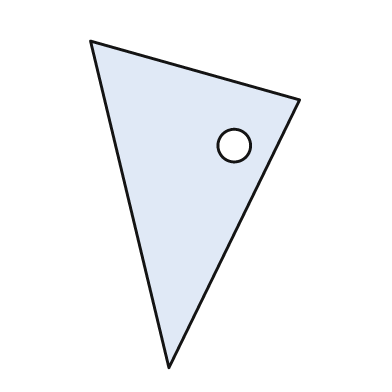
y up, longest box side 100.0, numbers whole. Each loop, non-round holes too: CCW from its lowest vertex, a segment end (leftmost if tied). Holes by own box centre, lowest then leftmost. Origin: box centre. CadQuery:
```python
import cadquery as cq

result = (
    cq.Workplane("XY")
    .moveTo(-8.0, -50.0)
    .lineTo(32.0, 32.0)
    .lineTo(-32.0, 50.0)
    .close()
    .moveTo(12.0, 18.0)
    .circle(5.0)
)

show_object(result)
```